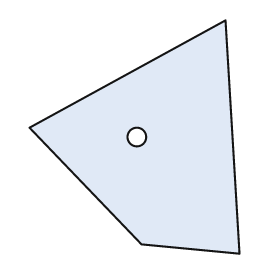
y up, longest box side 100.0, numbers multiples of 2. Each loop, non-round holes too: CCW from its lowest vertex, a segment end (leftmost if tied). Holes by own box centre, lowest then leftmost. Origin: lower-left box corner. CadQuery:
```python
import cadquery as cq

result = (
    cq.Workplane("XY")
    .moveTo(90.0, 0.0)
    .lineTo(84.0, 100.0)
    .lineTo(0.0, 54.0)
    .lineTo(48.0, 4.0)
    .close()
    .moveTo(46.0, 50.0)
    .circle(4.0)
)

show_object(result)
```